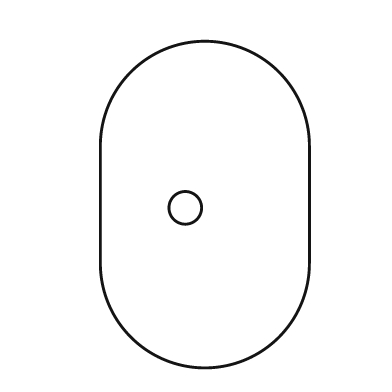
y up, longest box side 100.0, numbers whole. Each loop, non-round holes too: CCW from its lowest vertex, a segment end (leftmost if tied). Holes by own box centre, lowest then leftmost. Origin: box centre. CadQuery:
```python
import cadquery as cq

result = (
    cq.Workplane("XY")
    .moveTo(-32.0, -18.0)
    .threePointArc((0.0, -50.0), (32.0, -18.0))
    .lineTo(32.0, 18.0)
    .threePointArc((0.0, 50.0), (-32.0, 18.0))
    .close()
    .moveTo(-6.0, -1.0)
    .circle(5.0)
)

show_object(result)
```